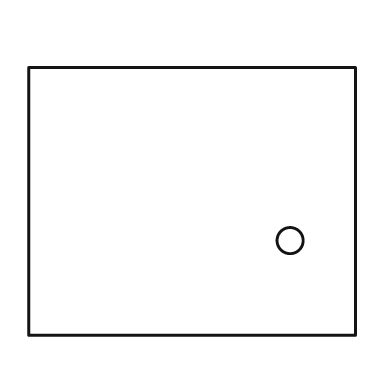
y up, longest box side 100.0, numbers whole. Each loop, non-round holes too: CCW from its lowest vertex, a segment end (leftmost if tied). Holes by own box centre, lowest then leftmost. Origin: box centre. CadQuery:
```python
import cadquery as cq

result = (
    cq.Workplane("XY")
    .moveTo(-50.0, -41.0)
    .lineTo(50.0, -41.0)
    .lineTo(50.0, 41.0)
    .lineTo(-50.0, 41.0)
    .close()
    .moveTo(30.0, -12.0)
    .circle(4.0)
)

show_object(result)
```